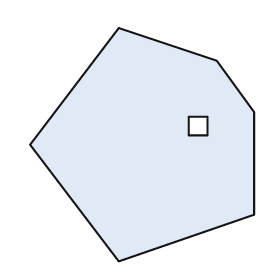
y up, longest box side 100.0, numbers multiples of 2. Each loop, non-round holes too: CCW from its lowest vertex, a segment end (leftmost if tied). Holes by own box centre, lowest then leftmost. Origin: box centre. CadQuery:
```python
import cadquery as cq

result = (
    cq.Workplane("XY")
    .moveTo(-10.0, -50.0)
    .lineTo(48.0, -30.0)
    .lineTo(48.0, 14.0)
    .lineTo(32.0, 36.0)
    .lineTo(-10.0, 50.0)
    .lineTo(-48.0, 0.0)
    .close()
    .moveTo(20.0, 4.0)
    .lineTo(28.0, 4.0)
    .lineTo(28.0, 12.0)
    .lineTo(20.0, 12.0)
    .close()
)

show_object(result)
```